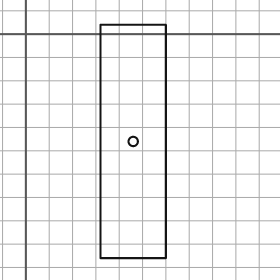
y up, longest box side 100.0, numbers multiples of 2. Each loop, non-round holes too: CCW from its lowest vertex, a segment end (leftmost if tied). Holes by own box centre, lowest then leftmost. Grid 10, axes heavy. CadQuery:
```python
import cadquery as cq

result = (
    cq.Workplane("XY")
    .moveTo(32.0, -96.0)
    .lineTo(60.0, -96.0)
    .lineTo(60.0, 4.0)
    .lineTo(32.0, 4.0)
    .close()
    .moveTo(46.0, -46.0)
    .circle(2.0)
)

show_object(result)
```